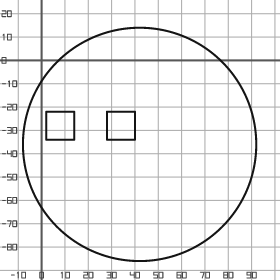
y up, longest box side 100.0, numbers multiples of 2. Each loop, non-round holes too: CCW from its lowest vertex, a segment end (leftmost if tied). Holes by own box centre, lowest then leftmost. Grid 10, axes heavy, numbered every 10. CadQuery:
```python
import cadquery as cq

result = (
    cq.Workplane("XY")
    .moveTo(42.0, -36.0)
    .circle(50.0)
    .moveTo(2.0, -34.0)
    .lineTo(14.0, -34.0)
    .lineTo(14.0, -22.0)
    .lineTo(2.0, -22.0)
    .close()
    .moveTo(28.0, -34.0)
    .lineTo(40.0, -34.0)
    .lineTo(40.0, -22.0)
    .lineTo(28.0, -22.0)
    .close()
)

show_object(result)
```